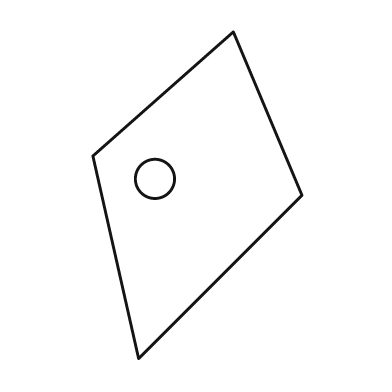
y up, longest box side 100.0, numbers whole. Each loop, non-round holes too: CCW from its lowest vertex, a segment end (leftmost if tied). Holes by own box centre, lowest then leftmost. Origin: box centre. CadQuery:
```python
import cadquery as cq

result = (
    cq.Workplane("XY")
    .moveTo(-18.0, -50.0)
    .lineTo(32.0, 0.0)
    .lineTo(11.0, 50.0)
    .lineTo(-32.0, 12.0)
    .close()
    .moveTo(-13.0, 5.0)
    .circle(6.0)
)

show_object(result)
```